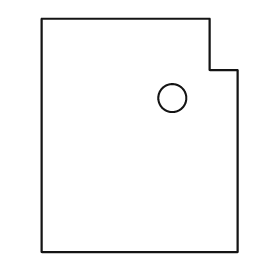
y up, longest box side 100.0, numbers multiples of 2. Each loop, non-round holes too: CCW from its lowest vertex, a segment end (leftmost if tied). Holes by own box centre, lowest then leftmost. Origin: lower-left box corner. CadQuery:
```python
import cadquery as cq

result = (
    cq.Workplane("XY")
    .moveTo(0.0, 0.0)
    .lineTo(84.0, 0.0)
    .lineTo(84.0, 78.0)
    .lineTo(72.0, 78.0)
    .lineTo(72.0, 100.0)
    .lineTo(0.0, 100.0)
    .close()
    .moveTo(56.0, 66.0)
    .circle(6.0)
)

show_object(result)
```